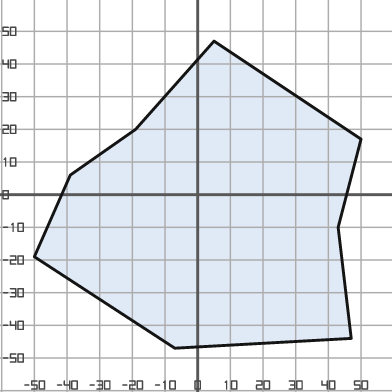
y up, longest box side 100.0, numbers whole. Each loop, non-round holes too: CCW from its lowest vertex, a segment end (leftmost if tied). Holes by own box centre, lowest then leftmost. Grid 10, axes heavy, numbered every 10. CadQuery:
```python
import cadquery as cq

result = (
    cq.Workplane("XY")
    .moveTo(-7.0, -47.0)
    .lineTo(47.0, -44.0)
    .lineTo(43.0, -10.0)
    .lineTo(50.0, 17.0)
    .lineTo(5.0, 47.0)
    .lineTo(-19.0, 20.0)
    .lineTo(-39.0, 6.0)
    .lineTo(-50.0, -19.0)
    .close()
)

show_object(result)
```